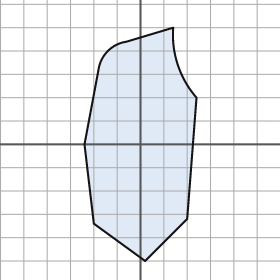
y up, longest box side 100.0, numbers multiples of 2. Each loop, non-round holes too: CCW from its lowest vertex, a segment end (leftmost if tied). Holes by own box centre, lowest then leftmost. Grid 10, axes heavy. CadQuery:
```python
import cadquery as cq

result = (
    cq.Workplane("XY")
    .moveTo(2.0, -50.0)
    .lineTo(20.0, -32.0)
    .lineTo(24.0, 20.0)
    .threePointArc((16.0, 34.0), (14.0, 50.0))
    .lineTo(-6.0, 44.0)
    .threePointArc((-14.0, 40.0), (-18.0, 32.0))
    .lineTo(-24.0, 0.0)
    .lineTo(-20.0, -34.0)
    .close()
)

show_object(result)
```